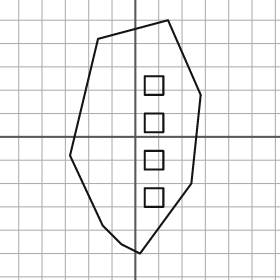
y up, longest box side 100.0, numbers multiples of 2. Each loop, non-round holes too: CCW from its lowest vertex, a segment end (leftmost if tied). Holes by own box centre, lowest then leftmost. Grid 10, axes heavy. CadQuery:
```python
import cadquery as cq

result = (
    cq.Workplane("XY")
    .moveTo(2.0, -50.0)
    .lineTo(24.0, -20.0)
    .lineTo(28.0, 18.0)
    .lineTo(14.0, 50.0)
    .lineTo(-16.0, 42.0)
    .lineTo(-28.0, -8.0)
    .lineTo(-14.0, -38.0)
    .lineTo(-6.0, -46.0)
    .close()
    .moveTo(4.0, -30.0)
    .lineTo(12.0, -30.0)
    .lineTo(12.0, -22.0)
    .lineTo(4.0, -22.0)
    .close()
    .moveTo(4.0, -14.0)
    .lineTo(12.0, -14.0)
    .lineTo(12.0, -6.0)
    .lineTo(4.0, -6.0)
    .close()
    .moveTo(4.0, 2.0)
    .lineTo(12.0, 2.0)
    .lineTo(12.0, 10.0)
    .lineTo(4.0, 10.0)
    .close()
    .moveTo(4.0, 18.0)
    .lineTo(12.0, 18.0)
    .lineTo(12.0, 26.0)
    .lineTo(4.0, 26.0)
    .close()
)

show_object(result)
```